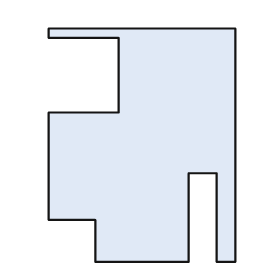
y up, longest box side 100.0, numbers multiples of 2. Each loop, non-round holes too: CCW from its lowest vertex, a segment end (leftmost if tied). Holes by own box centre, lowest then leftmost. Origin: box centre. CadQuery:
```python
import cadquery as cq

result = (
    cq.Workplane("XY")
    .moveTo(-20.0, -50.0)
    .lineTo(20.0, -50.0)
    .lineTo(20.0, -12.0)
    .lineTo(32.0, -12.0)
    .lineTo(32.0, -50.0)
    .lineTo(40.0, -50.0)
    .lineTo(40.0, 50.0)
    .lineTo(-40.0, 50.0)
    .lineTo(-40.0, 46.0)
    .lineTo(-10.0, 46.0)
    .lineTo(-10.0, 14.0)
    .lineTo(-40.0, 14.0)
    .lineTo(-40.0, -32.0)
    .lineTo(-20.0, -32.0)
    .close()
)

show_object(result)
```